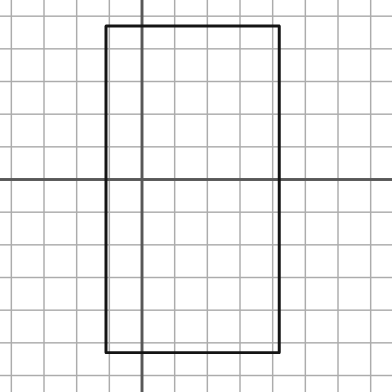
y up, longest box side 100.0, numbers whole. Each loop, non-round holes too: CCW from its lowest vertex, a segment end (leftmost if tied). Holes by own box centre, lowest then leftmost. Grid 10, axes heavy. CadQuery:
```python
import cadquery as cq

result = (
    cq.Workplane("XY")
    .moveTo(-11.0, -53.0)
    .lineTo(42.0, -53.0)
    .lineTo(42.0, 47.0)
    .lineTo(-11.0, 47.0)
    .close()
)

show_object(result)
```